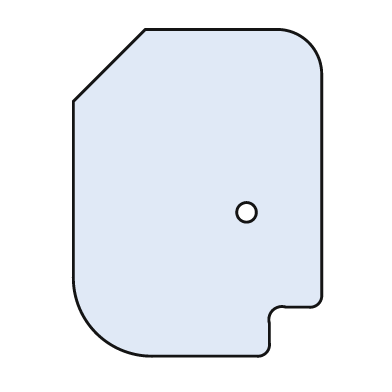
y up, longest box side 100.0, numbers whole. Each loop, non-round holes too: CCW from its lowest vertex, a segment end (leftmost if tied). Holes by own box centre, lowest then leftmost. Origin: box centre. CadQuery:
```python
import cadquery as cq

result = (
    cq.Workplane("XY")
    .moveTo(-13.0, -50.0)
    .lineTo(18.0, -50.0)
    .threePointArc((21.0, -49.0), (22.0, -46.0))
    .lineTo(22.0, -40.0)
    .threePointArc((23.0, -36.0), (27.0, -35.0))
    .lineTo(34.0, -35.0)
    .threePointArc((37.0, -34.0), (38.0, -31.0))
    .lineTo(38.0, 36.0)
    .threePointArc((34.0, 46.0), (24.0, 50.0))
    .lineTo(-16.0, 50.0)
    .lineTo(-38.0, 28.0)
    .lineTo(-38.0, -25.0)
    .threePointArc((-31.0, -43.0), (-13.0, -50.0))
    .close()
    .moveTo(15.0, -6.0)
    .circle(3.0)
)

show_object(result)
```